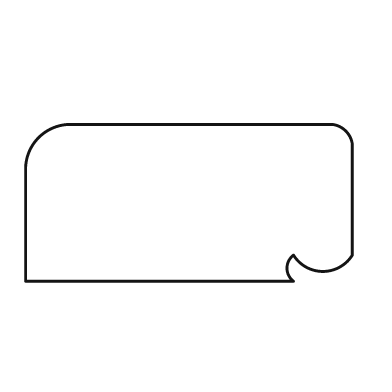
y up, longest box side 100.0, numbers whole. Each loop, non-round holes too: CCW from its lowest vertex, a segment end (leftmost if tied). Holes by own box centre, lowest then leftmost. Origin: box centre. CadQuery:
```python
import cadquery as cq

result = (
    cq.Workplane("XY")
    .moveTo(-50.0, -24.0)
    .lineTo(32.0, -24.0)
    .threePointArc((30.0, -20.0), (32.0, -16.0))
    .threePointArc((41.0, -21.0), (50.0, -16.0))
    .lineTo(50.0, 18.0)
    .threePointArc((48.0, 22.0), (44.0, 24.0))
    .lineTo(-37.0, 24.0)
    .threePointArc((-46.0, 20.0), (-50.0, 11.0))
    .close()
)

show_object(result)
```